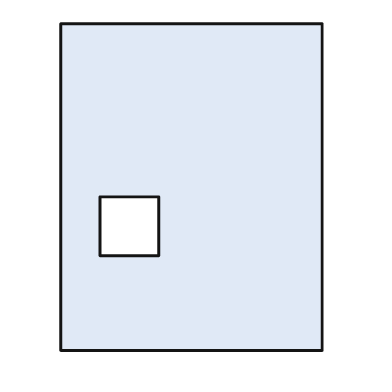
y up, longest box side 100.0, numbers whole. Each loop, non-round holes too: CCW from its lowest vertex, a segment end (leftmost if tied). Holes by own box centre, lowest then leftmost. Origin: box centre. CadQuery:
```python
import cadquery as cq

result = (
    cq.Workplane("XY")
    .moveTo(-40.0, -50.0)
    .lineTo(40.0, -50.0)
    .lineTo(40.0, 50.0)
    .lineTo(-40.0, 50.0)
    .close()
    .moveTo(-28.0, -21.0)
    .lineTo(-10.0, -21.0)
    .lineTo(-10.0, -3.0)
    .lineTo(-28.0, -3.0)
    .close()
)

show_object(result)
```